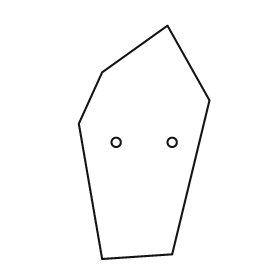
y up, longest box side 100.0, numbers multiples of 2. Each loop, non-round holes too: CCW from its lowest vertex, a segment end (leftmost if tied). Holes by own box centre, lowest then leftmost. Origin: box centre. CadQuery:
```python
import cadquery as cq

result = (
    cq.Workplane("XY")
    .moveTo(-18.0, -50.0)
    .lineTo(12.0, -48.0)
    .lineTo(28.0, 18.0)
    .lineTo(10.0, 50.0)
    .lineTo(-18.0, 30.0)
    .lineTo(-28.0, 8.0)
    .close()
    .moveTo(-12.0, 0.0)
    .circle(2.0)
    .moveTo(12.0, 0.0)
    .circle(2.0)
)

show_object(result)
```